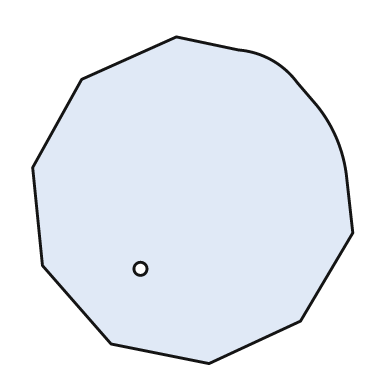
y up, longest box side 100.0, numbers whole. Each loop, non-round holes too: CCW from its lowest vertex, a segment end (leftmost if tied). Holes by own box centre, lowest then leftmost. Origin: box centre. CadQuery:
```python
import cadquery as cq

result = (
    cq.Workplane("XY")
    .moveTo(5.0, -50.0)
    .lineTo(33.0, -37.0)
    .lineTo(49.0, -10.0)
    .lineTo(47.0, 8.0)
    .threePointArc((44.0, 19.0), (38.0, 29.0))
    .lineTo(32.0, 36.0)
    .threePointArc((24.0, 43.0), (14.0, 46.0))
    .lineTo(-5.0, 50.0)
    .lineTo(-34.0, 37.0)
    .lineTo(-49.0, 10.0)
    .lineTo(-46.0, -20.0)
    .lineTo(-25.0, -44.0)
    .close()
    .moveTo(-16.0, -21.0)
    .circle(2.0)
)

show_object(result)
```